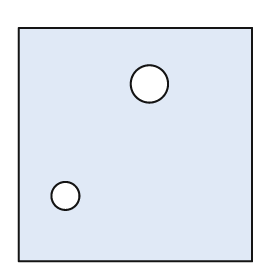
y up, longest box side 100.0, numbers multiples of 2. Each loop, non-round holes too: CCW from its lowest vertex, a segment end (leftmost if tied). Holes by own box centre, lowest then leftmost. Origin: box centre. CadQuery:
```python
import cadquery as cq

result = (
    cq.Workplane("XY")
    .moveTo(-50.0, -50.0)
    .lineTo(50.0, -50.0)
    .lineTo(50.0, 50.0)
    .lineTo(-50.0, 50.0)
    .close()
    .moveTo(-30.0, -22.0)
    .circle(6.0)
    .moveTo(6.0, 26.0)
    .circle(8.0)
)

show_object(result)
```